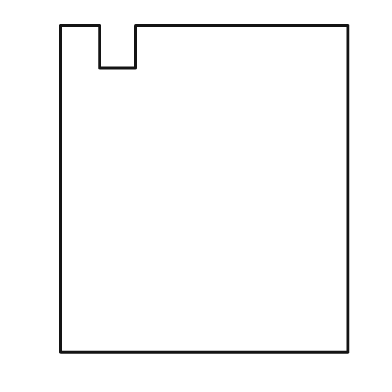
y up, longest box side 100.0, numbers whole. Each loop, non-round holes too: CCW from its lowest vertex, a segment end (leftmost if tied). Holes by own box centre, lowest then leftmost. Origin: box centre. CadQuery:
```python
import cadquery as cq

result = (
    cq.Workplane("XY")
    .moveTo(-44.0, -50.0)
    .lineTo(44.0, -50.0)
    .lineTo(44.0, 50.0)
    .lineTo(-21.0, 50.0)
    .lineTo(-21.0, 37.0)
    .lineTo(-32.0, 37.0)
    .lineTo(-32.0, 50.0)
    .lineTo(-44.0, 50.0)
    .close()
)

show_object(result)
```